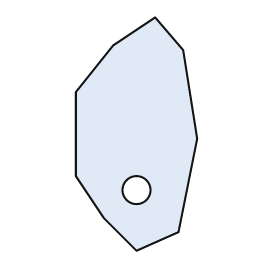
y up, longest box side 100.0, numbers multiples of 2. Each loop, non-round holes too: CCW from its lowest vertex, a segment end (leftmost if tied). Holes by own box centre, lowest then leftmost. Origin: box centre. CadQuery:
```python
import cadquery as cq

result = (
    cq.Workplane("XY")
    .moveTo(0.0, -50.0)
    .lineTo(18.0, -42.0)
    .lineTo(26.0, -2.0)
    .lineTo(20.0, 36.0)
    .lineTo(8.0, 50.0)
    .lineTo(-10.0, 38.0)
    .lineTo(-26.0, 18.0)
    .lineTo(-26.0, -18.0)
    .lineTo(-14.0, -36.0)
    .close()
    .moveTo(0.0, -24.0)
    .circle(6.0)
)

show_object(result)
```